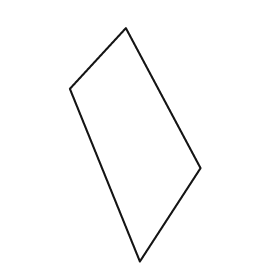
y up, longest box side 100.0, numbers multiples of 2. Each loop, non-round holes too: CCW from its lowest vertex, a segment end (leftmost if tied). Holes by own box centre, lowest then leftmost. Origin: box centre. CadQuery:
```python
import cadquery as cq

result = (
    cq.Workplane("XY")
    .moveTo(2.0, -50.0)
    .lineTo(28.0, -10.0)
    .lineTo(-4.0, 50.0)
    .lineTo(-28.0, 24.0)
    .close()
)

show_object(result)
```